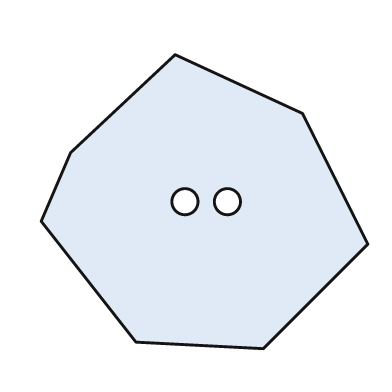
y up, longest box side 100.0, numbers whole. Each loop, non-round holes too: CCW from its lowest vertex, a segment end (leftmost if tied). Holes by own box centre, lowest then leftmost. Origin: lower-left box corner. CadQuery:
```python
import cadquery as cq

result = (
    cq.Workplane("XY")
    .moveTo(68.0, 0.0)
    .lineTo(100.0, 32.0)
    .lineTo(80.0, 72.0)
    .lineTo(41.0, 90.0)
    .lineTo(9.0, 60.0)
    .lineTo(0.0, 39.0)
    .lineTo(29.0, 2.0)
    .close()
    .moveTo(44.0, 45.0)
    .circle(4.0)
    .moveTo(57.0, 45.0)
    .circle(4.0)
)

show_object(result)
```